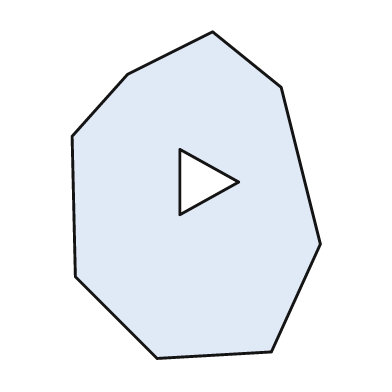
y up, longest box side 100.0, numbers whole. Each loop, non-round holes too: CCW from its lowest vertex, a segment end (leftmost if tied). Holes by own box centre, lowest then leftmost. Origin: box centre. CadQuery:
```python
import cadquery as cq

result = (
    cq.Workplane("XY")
    .moveTo(-12.0, -50.0)
    .lineTo(23.0, -48.0)
    .lineTo(38.0, -15.0)
    .lineTo(26.0, 33.0)
    .lineTo(5.0, 50.0)
    .lineTo(-21.0, 37.0)
    .lineTo(-38.0, 18.0)
    .lineTo(-37.0, -25.0)
    .close()
    .moveTo(-5.0, -6.0)
    .lineTo(13.0, 4.0)
    .lineTo(-5.0, 14.0)
    .close()
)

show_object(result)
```